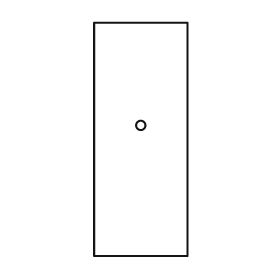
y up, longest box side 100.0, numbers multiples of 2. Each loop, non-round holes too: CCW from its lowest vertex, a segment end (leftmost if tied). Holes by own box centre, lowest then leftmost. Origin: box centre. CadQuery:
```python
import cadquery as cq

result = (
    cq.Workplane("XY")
    .moveTo(-20.0, -50.0)
    .lineTo(20.0, -50.0)
    .lineTo(20.0, 50.0)
    .lineTo(-20.0, 50.0)
    .close()
    .moveTo(0.0, 6.0)
    .circle(2.0)
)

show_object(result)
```